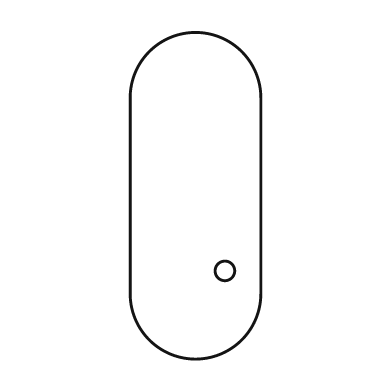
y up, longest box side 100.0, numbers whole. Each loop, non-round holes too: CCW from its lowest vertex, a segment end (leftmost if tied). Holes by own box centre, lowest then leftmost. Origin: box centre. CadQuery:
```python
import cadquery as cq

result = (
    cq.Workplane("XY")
    .moveTo(-20.0, -30.0)
    .threePointArc((0.0, -50.0), (20.0, -30.0))
    .lineTo(20.0, 30.0)
    .threePointArc((0.0, 50.0), (-20.0, 30.0))
    .close()
    .moveTo(9.0, -23.0)
    .circle(3.0)
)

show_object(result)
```